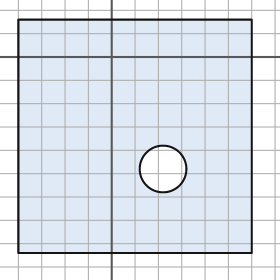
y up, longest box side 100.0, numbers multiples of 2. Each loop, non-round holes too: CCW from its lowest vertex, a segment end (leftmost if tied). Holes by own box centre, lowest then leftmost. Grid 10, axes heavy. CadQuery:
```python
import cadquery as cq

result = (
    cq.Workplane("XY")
    .moveTo(-40.0, -84.0)
    .lineTo(60.0, -84.0)
    .lineTo(60.0, 16.0)
    .lineTo(-40.0, 16.0)
    .close()
    .moveTo(22.0, -48.0)
    .circle(10.0)
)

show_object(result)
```